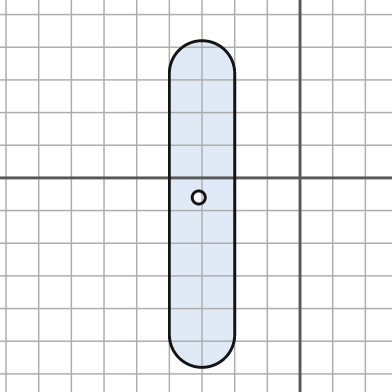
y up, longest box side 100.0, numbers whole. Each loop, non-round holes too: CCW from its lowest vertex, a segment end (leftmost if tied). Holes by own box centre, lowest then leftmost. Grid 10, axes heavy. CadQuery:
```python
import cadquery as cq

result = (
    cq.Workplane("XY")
    .moveTo(-40.0, -48.0)
    .threePointArc((-30.0, -58.0), (-20.0, -48.0))
    .lineTo(-20.0, 32.0)
    .threePointArc((-30.0, 42.0), (-40.0, 32.0))
    .close()
    .moveTo(-31.0, -6.0)
    .circle(2.0)
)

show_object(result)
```